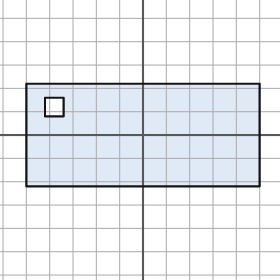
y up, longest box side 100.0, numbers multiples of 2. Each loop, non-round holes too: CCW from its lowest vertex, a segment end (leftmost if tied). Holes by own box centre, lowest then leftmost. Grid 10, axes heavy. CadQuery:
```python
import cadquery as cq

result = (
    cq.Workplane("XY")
    .moveTo(-50.0, -22.0)
    .lineTo(50.0, -22.0)
    .lineTo(50.0, 22.0)
    .lineTo(-50.0, 22.0)
    .close()
    .moveTo(-42.0, 8.0)
    .lineTo(-34.0, 8.0)
    .lineTo(-34.0, 16.0)
    .lineTo(-42.0, 16.0)
    .close()
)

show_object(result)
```